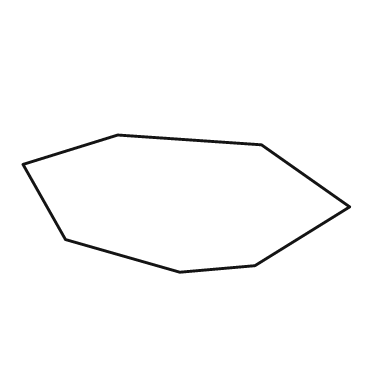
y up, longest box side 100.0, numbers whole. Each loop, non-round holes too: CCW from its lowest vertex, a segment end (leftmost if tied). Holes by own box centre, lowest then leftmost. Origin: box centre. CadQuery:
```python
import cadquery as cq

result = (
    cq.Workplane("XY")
    .moveTo(-2.0, -21.0)
    .lineTo(21.0, -19.0)
    .lineTo(50.0, -1.0)
    .lineTo(23.0, 18.0)
    .lineTo(-21.0, 21.0)
    .lineTo(-50.0, 12.0)
    .lineTo(-37.0, -11.0)
    .close()
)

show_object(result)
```